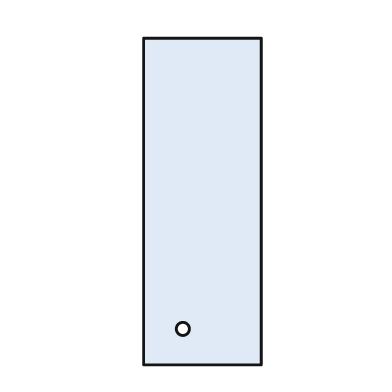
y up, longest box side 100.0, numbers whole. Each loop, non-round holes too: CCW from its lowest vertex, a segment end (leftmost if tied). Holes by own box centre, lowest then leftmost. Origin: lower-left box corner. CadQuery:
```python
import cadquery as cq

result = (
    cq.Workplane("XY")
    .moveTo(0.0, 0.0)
    .lineTo(36.0, 0.0)
    .lineTo(36.0, 100.0)
    .lineTo(0.0, 100.0)
    .close()
    .moveTo(12.0, 11.0)
    .circle(2.0)
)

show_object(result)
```